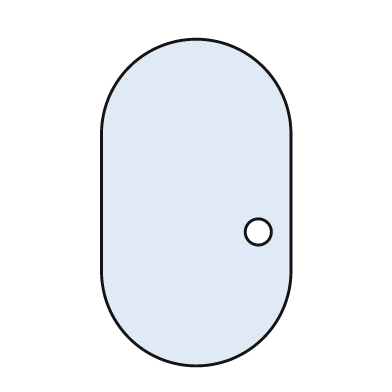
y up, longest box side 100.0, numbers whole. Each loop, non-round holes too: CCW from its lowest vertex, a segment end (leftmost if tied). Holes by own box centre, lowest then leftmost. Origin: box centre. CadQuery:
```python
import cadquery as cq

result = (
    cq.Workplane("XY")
    .moveTo(-29.0, -21.0)
    .threePointArc((0.0, -50.0), (29.0, -21.0))
    .lineTo(29.0, 21.0)
    .threePointArc((0.0, 50.0), (-29.0, 21.0))
    .close()
    .moveTo(19.0, -9.0)
    .circle(4.0)
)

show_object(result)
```